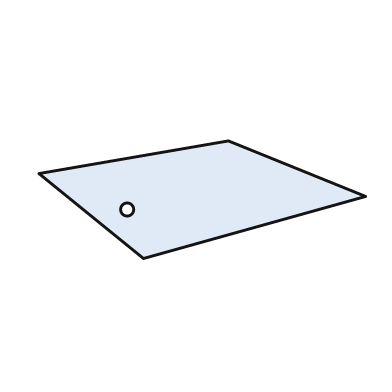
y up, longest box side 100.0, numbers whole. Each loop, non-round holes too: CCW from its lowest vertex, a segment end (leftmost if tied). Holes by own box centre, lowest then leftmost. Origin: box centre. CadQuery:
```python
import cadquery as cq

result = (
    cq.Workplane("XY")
    .moveTo(-18.0, -18.0)
    .lineTo(50.0, 1.0)
    .lineTo(8.0, 18.0)
    .lineTo(-50.0, 8.0)
    .close()
    .moveTo(-23.0, -3.0)
    .circle(2.0)
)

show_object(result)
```